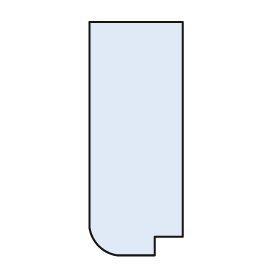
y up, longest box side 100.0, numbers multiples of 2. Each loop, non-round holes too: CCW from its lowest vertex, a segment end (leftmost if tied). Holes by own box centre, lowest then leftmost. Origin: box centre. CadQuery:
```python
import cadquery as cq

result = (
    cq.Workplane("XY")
    .moveTo(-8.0, -50.0)
    .lineTo(8.0, -50.0)
    .lineTo(8.0, -42.0)
    .lineTo(20.0, -42.0)
    .lineTo(20.0, 50.0)
    .lineTo(-20.0, 50.0)
    .lineTo(-20.0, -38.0)
    .threePointArc((-16.0, -46.0), (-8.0, -50.0))
    .close()
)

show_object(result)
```